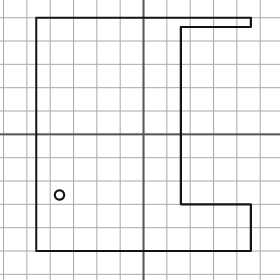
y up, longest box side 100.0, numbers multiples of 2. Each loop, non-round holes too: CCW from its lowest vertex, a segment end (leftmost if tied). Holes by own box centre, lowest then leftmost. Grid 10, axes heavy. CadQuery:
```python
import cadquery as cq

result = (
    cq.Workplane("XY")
    .moveTo(-46.0, -50.0)
    .lineTo(46.0, -50.0)
    .lineTo(46.0, -30.0)
    .lineTo(16.0, -30.0)
    .lineTo(16.0, 46.0)
    .lineTo(46.0, 46.0)
    .lineTo(46.0, 50.0)
    .lineTo(-46.0, 50.0)
    .close()
    .moveTo(-36.0, -26.0)
    .circle(2.0)
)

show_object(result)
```